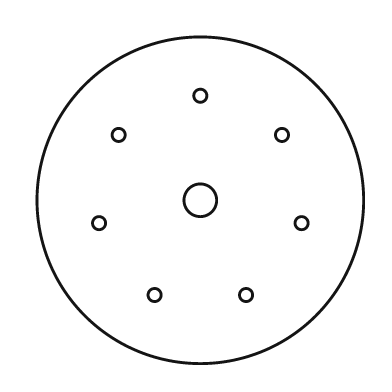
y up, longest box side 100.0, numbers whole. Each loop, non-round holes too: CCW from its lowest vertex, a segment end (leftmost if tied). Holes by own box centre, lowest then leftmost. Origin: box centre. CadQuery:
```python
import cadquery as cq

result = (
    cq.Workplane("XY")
    .moveTo(0.0, 0.0)
    .circle(50.0)
    .moveTo(-14.0, -29.0)
    .circle(2.0)
    .moveTo(14.0, -29.0)
    .circle(2.0)
    .moveTo(-31.0, -7.0)
    .circle(2.0)
    .moveTo(31.0, -7.0)
    .circle(2.0)
    .moveTo(0.0, 0.0)
    .circle(5.0)
    .moveTo(-25.0, 20.0)
    .circle(2.0)
    .moveTo(25.0, 20.0)
    .circle(2.0)
    .moveTo(0.0, 32.0)
    .circle(2.0)
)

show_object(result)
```